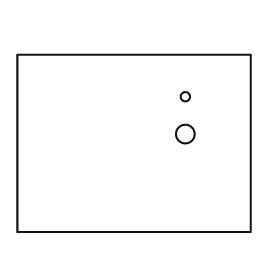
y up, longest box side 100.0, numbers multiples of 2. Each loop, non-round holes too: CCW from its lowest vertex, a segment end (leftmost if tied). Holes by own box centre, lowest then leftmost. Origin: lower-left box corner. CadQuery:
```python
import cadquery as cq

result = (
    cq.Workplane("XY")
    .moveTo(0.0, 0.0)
    .lineTo(100.0, 0.0)
    .lineTo(100.0, 76.0)
    .lineTo(0.0, 76.0)
    .close()
    .moveTo(72.0, 42.0)
    .circle(4.0)
    .moveTo(72.0, 58.0)
    .circle(2.0)
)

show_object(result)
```